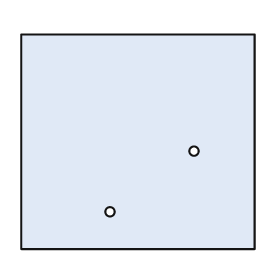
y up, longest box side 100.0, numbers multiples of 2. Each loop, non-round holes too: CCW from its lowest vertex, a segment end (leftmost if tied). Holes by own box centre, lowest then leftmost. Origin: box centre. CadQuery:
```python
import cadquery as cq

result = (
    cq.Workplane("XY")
    .moveTo(-50.0, -46.0)
    .lineTo(50.0, -46.0)
    .lineTo(50.0, 46.0)
    .lineTo(-50.0, 46.0)
    .close()
    .moveTo(-12.0, -30.0)
    .circle(2.0)
    .moveTo(24.0, -4.0)
    .circle(2.0)
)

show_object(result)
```